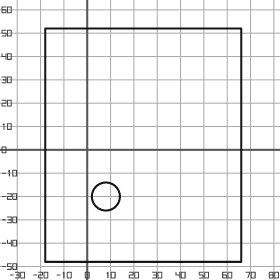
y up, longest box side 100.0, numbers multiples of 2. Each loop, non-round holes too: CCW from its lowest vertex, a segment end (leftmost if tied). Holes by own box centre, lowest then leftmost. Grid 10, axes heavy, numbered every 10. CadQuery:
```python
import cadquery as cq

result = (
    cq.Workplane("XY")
    .moveTo(-18.0, -48.0)
    .lineTo(66.0, -48.0)
    .lineTo(66.0, 52.0)
    .lineTo(-18.0, 52.0)
    .close()
    .moveTo(8.0, -20.0)
    .circle(6.0)
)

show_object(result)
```